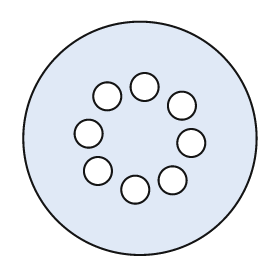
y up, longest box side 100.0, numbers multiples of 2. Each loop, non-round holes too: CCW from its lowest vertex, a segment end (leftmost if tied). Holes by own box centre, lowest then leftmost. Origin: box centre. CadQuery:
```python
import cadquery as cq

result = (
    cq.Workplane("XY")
    .moveTo(0.0, 0.0)
    .circle(50.0)
    .moveTo(-2.0, -22.0)
    .circle(6.0)
    .moveTo(14.0, -18.0)
    .circle(6.0)
    .moveTo(-18.0, -14.0)
    .circle(6.0)
    .moveTo(22.0, -2.0)
    .circle(6.0)
    .moveTo(-22.0, 2.0)
    .circle(6.0)
    .moveTo(18.0, 14.0)
    .circle(6.0)
    .moveTo(-14.0, 18.0)
    .circle(6.0)
    .moveTo(2.0, 22.0)
    .circle(6.0)
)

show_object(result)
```